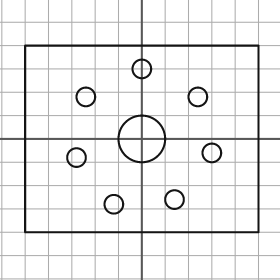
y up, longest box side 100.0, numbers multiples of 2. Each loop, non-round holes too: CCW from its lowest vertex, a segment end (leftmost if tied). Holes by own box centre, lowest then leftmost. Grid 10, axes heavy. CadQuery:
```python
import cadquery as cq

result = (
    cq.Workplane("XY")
    .moveTo(-50.0, -40.0)
    .lineTo(50.0, -40.0)
    .lineTo(50.0, 40.0)
    .lineTo(-50.0, 40.0)
    .close()
    .moveTo(-12.0, -28.0)
    .circle(4.0)
    .moveTo(14.0, -26.0)
    .circle(4.0)
    .moveTo(-28.0, -8.0)
    .circle(4.0)
    .moveTo(30.0, -6.0)
    .circle(4.0)
    .moveTo(0.0, 0.0)
    .circle(10.0)
    .moveTo(-24.0, 18.0)
    .circle(4.0)
    .moveTo(24.0, 18.0)
    .circle(4.0)
    .moveTo(0.0, 30.0)
    .circle(4.0)
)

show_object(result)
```